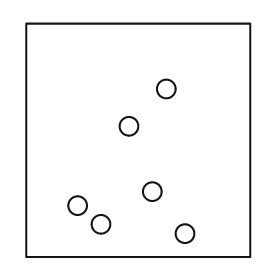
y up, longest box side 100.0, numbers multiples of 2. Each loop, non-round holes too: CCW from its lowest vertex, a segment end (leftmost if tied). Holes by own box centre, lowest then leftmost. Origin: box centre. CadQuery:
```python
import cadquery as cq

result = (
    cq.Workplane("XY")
    .moveTo(-48.0, -50.0)
    .lineTo(48.0, -50.0)
    .lineTo(48.0, 50.0)
    .lineTo(-48.0, 50.0)
    .close()
    .moveTo(20.0, -40.0)
    .circle(4.0)
    .moveTo(-16.0, -36.0)
    .circle(4.0)
    .moveTo(-26.0, -28.0)
    .circle(4.0)
    .moveTo(6.0, -22.0)
    .circle(4.0)
    .moveTo(-4.0, 6.0)
    .circle(4.0)
    .moveTo(12.0, 22.0)
    .circle(4.0)
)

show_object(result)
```